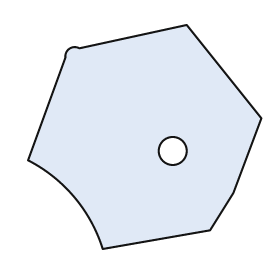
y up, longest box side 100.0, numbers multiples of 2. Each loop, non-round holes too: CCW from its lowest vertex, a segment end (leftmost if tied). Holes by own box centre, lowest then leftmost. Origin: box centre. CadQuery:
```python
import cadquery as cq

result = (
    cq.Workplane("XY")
    .moveTo(-18.0, -48.0)
    .lineTo(28.0, -40.0)
    .lineTo(38.0, -24.0)
    .lineTo(50.0, 8.0)
    .lineTo(18.0, 48.0)
    .lineTo(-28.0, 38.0)
    .threePointArc((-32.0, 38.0), (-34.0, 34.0))
    .lineTo(-50.0, -10.0)
    .threePointArc((-30.0, -26.0), (-18.0, -48.0))
    .close()
    .moveTo(12.0, -6.0)
    .circle(6.0)
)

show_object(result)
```